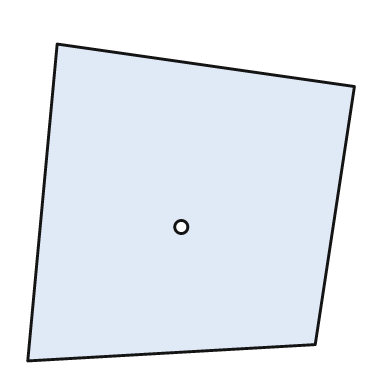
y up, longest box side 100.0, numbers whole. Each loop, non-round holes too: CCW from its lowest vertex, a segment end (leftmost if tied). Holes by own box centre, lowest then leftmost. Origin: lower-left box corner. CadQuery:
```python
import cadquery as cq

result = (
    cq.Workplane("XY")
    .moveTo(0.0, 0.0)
    .lineTo(88.0, 5.0)
    .lineTo(100.0, 84.0)
    .lineTo(9.0, 97.0)
    .close()
    .moveTo(47.0, 41.0)
    .circle(2.0)
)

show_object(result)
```